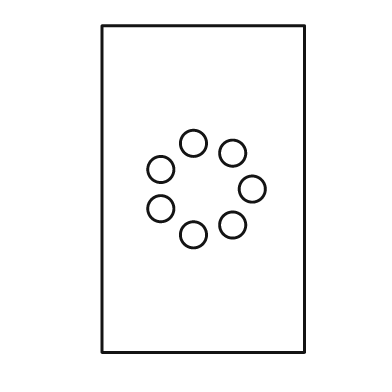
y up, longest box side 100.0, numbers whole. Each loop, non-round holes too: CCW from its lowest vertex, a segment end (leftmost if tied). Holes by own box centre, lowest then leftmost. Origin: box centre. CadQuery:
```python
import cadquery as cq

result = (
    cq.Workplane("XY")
    .moveTo(-31.0, -50.0)
    .lineTo(31.0, -50.0)
    .lineTo(31.0, 50.0)
    .lineTo(-31.0, 50.0)
    .close()
    .moveTo(-3.0, -14.0)
    .circle(4.0)
    .moveTo(9.0, -11.0)
    .circle(4.0)
    .moveTo(-13.0, -6.0)
    .circle(4.0)
    .moveTo(15.0, 0.0)
    .circle(4.0)
    .moveTo(-13.0, 6.0)
    .circle(4.0)
    .moveTo(9.0, 11.0)
    .circle(4.0)
    .moveTo(-3.0, 14.0)
    .circle(4.0)
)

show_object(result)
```